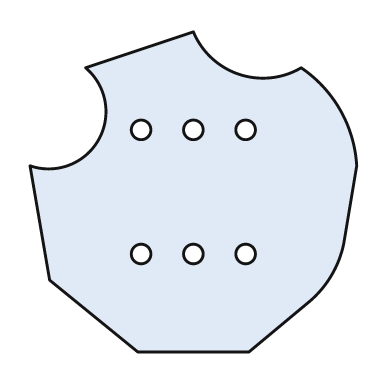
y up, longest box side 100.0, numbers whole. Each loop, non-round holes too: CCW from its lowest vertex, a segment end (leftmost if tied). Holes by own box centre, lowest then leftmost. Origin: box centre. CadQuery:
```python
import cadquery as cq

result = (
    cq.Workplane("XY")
    .moveTo(-17.0, -49.0)
    .lineTo(17.0, -49.0)
    .lineTo(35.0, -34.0)
    .threePointArc((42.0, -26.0), (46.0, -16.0))
    .lineTo(50.0, 8.0)
    .threePointArc((45.0, 25.0), (33.0, 38.0))
    .threePointArc((14.0, 36.0), (0.0, 49.0))
    .lineTo(-33.0, 38.0)
    .threePointArc((-29.0, 16.0), (-50.0, 8.0))
    .lineTo(-44.0, -27.0)
    .close()
    .moveTo(-16.0, -19.0)
    .circle(3.0)
    .moveTo(0.0, -19.0)
    .circle(3.0)
    .moveTo(16.0, -19.0)
    .circle(3.0)
    .moveTo(-16.0, 19.0)
    .circle(3.0)
    .moveTo(0.0, 19.0)
    .circle(3.0)
    .moveTo(16.0, 19.0)
    .circle(3.0)
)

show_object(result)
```